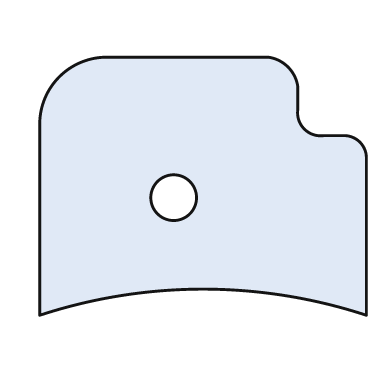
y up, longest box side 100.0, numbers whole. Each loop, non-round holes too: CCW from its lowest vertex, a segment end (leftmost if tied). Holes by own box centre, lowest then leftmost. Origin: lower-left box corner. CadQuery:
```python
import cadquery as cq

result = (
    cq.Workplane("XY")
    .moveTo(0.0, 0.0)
    .threePointArc((50.0, 8.0), (100.0, 0.0))
    .lineTo(100.0, 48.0)
    .threePointArc((98.0, 53.0), (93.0, 55.0))
    .lineTo(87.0, 55.0)
    .threePointArc((81.0, 57.0), (79.0, 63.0))
    .lineTo(79.0, 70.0)
    .threePointArc((76.0, 76.0), (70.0, 79.0))
    .lineTo(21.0, 79.0)
    .threePointArc((6.0, 73.0), (0.0, 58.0))
    .close()
    .moveTo(41.0, 36.0)
    .circle(7.0)
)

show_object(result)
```